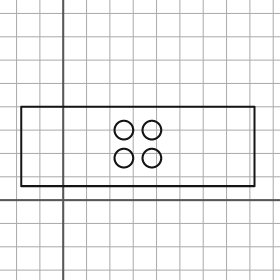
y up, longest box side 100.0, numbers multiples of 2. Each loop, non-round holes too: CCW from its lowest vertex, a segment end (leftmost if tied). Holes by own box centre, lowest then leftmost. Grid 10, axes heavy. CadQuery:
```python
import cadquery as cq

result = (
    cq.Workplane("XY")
    .moveTo(-18.0, 6.0)
    .lineTo(82.0, 6.0)
    .lineTo(82.0, 40.0)
    .lineTo(-18.0, 40.0)
    .close()
    .moveTo(26.0, 18.0)
    .circle(4.0)
    .moveTo(38.0, 18.0)
    .circle(4.0)
    .moveTo(26.0, 30.0)
    .circle(4.0)
    .moveTo(38.0, 30.0)
    .circle(4.0)
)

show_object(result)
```